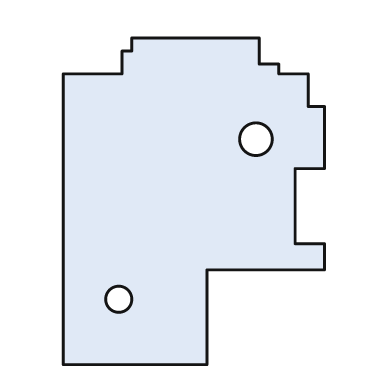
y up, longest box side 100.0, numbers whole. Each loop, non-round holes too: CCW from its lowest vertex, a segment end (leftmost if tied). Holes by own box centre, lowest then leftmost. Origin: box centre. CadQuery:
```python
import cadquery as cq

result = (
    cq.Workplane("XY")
    .moveTo(-40.0, -50.0)
    .lineTo(4.0, -50.0)
    .lineTo(4.0, -21.0)
    .lineTo(40.0, -21.0)
    .lineTo(40.0, -13.0)
    .lineTo(31.0, -13.0)
    .lineTo(31.0, 10.0)
    .lineTo(40.0, 10.0)
    .lineTo(40.0, 29.0)
    .lineTo(35.0, 29.0)
    .lineTo(35.0, 39.0)
    .lineTo(26.0, 39.0)
    .lineTo(26.0, 42.0)
    .lineTo(20.0, 42.0)
    .lineTo(20.0, 50.0)
    .lineTo(-19.0, 50.0)
    .lineTo(-19.0, 46.0)
    .lineTo(-22.0, 46.0)
    .lineTo(-22.0, 39.0)
    .lineTo(-40.0, 39.0)
    .close()
    .moveTo(-23.0, -30.0)
    .circle(4.0)
    .moveTo(19.0, 19.0)
    .circle(5.0)
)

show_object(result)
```